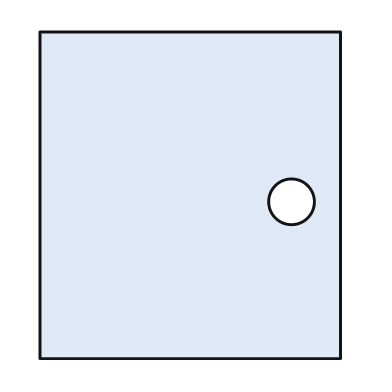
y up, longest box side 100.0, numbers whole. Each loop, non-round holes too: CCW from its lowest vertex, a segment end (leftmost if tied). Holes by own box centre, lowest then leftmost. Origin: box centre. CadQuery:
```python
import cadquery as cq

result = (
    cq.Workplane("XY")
    .moveTo(-46.0, -50.0)
    .lineTo(46.0, -50.0)
    .lineTo(46.0, 50.0)
    .lineTo(-46.0, 50.0)
    .close()
    .moveTo(31.0, -2.0)
    .circle(7.0)
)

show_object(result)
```